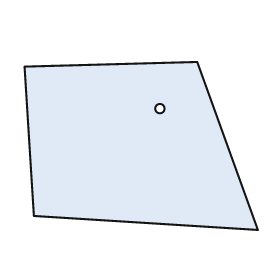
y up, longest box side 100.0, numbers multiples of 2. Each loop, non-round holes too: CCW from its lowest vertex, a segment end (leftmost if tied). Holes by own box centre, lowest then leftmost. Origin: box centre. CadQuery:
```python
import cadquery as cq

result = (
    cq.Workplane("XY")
    .moveTo(50.0, -36.0)
    .lineTo(24.0, 36.0)
    .lineTo(-50.0, 34.0)
    .lineTo(-46.0, -30.0)
    .close()
    .moveTo(8.0, 16.0)
    .circle(2.0)
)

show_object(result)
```